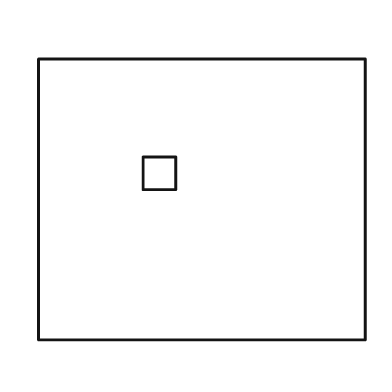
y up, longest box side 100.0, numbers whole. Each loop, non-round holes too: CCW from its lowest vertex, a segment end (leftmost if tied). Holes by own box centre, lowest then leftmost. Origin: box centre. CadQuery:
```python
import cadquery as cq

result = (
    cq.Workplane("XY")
    .moveTo(-50.0, -43.0)
    .lineTo(50.0, -43.0)
    .lineTo(50.0, 43.0)
    .lineTo(-50.0, 43.0)
    .close()
    .moveTo(-18.0, 3.0)
    .lineTo(-8.0, 3.0)
    .lineTo(-8.0, 13.0)
    .lineTo(-18.0, 13.0)
    .close()
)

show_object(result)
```